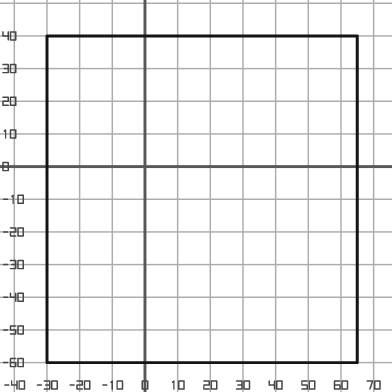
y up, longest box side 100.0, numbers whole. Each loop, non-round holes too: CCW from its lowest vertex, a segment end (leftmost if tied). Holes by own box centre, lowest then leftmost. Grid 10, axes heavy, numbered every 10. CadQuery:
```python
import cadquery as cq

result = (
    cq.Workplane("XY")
    .moveTo(-30.0, -60.0)
    .lineTo(65.0, -60.0)
    .lineTo(65.0, 40.0)
    .lineTo(-30.0, 40.0)
    .close()
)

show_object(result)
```